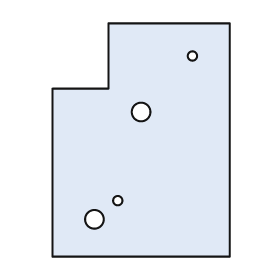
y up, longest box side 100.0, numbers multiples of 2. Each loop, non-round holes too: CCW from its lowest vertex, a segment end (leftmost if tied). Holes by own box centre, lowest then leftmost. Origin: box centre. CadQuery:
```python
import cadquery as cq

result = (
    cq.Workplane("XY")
    .moveTo(-38.0, -50.0)
    .lineTo(38.0, -50.0)
    .lineTo(38.0, 50.0)
    .lineTo(-14.0, 50.0)
    .lineTo(-14.0, 22.0)
    .lineTo(-38.0, 22.0)
    .close()
    .moveTo(-20.0, -34.0)
    .circle(4.0)
    .moveTo(-10.0, -26.0)
    .circle(2.0)
    .moveTo(0.0, 12.0)
    .circle(4.0)
    .moveTo(22.0, 36.0)
    .circle(2.0)
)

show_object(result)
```